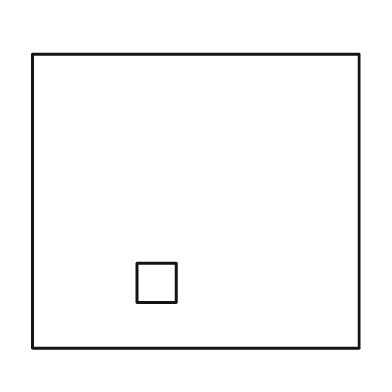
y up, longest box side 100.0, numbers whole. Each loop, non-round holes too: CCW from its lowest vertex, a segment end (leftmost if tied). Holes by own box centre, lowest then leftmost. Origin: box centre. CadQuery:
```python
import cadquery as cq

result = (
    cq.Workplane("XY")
    .moveTo(-50.0, -45.0)
    .lineTo(50.0, -45.0)
    .lineTo(50.0, 45.0)
    .lineTo(-50.0, 45.0)
    .close()
    .moveTo(-18.0, -31.0)
    .lineTo(-6.0, -31.0)
    .lineTo(-6.0, -19.0)
    .lineTo(-18.0, -19.0)
    .close()
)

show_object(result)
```